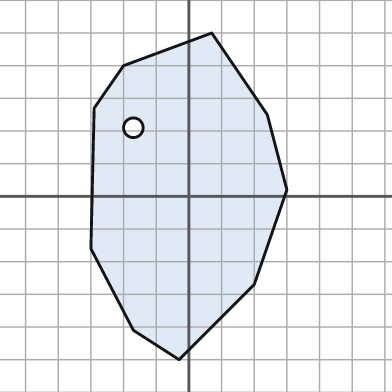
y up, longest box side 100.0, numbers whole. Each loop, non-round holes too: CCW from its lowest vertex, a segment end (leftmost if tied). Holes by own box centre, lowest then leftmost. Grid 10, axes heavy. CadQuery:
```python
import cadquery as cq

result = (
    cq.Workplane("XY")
    .moveTo(-3.0, -50.0)
    .lineTo(20.0, -27.0)
    .lineTo(30.0, 2.0)
    .lineTo(24.0, 25.0)
    .lineTo(7.0, 50.0)
    .lineTo(-20.0, 40.0)
    .lineTo(-29.0, 27.0)
    .lineTo(-30.0, -16.0)
    .lineTo(-17.0, -41.0)
    .close()
    .moveTo(-17.0, 21.0)
    .circle(3.0)
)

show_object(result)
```